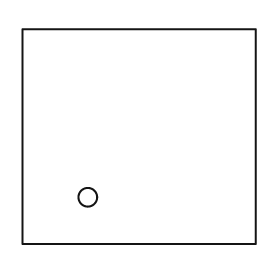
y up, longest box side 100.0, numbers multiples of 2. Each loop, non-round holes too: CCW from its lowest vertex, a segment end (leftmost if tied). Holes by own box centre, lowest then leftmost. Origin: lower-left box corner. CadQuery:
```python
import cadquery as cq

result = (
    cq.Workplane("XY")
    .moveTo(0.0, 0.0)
    .lineTo(100.0, 0.0)
    .lineTo(100.0, 92.0)
    .lineTo(0.0, 92.0)
    .close()
    .moveTo(28.0, 20.0)
    .circle(4.0)
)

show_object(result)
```